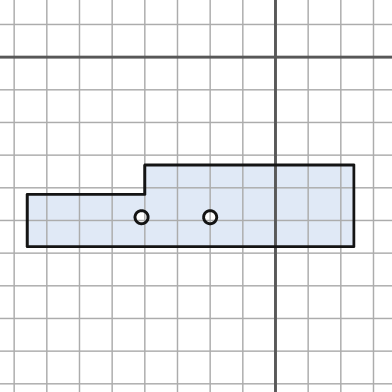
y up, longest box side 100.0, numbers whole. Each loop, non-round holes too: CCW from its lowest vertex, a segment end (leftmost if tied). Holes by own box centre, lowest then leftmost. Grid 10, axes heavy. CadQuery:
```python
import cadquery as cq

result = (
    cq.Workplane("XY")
    .moveTo(-76.0, -58.0)
    .lineTo(24.0, -58.0)
    .lineTo(24.0, -33.0)
    .lineTo(-40.0, -33.0)
    .lineTo(-40.0, -42.0)
    .lineTo(-76.0, -42.0)
    .close()
    .moveTo(-41.0, -49.0)
    .circle(2.0)
    .moveTo(-20.0, -49.0)
    .circle(2.0)
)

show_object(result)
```